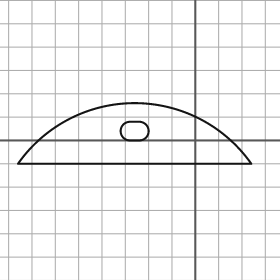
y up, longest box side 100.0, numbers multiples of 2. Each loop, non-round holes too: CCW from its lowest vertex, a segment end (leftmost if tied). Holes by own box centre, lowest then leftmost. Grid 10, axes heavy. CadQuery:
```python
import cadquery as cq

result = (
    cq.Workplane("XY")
    .moveTo(-76.0, -10.0)
    .lineTo(24.0, -10.0)
    .threePointArc((-26.0, 16.0), (-76.0, -10.0))
    .close()
    .moveTo(-28.0, 0.0)
    .lineTo(-24.0, 0.0)
    .threePointArc((-20.0, 4.0), (-24.0, 8.0))
    .lineTo(-28.0, 8.0)
    .threePointArc((-32.0, 4.0), (-28.0, 0.0))
    .close()
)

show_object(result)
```